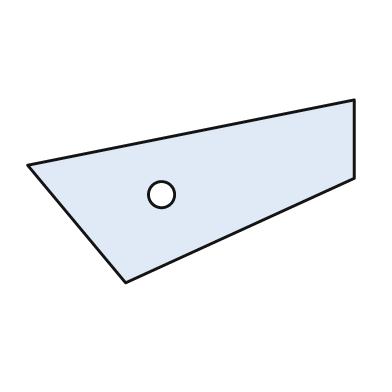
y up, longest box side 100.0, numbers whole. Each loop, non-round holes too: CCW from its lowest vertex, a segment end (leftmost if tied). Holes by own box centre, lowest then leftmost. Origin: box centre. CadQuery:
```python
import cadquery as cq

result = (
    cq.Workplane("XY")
    .moveTo(-20.0, -28.0)
    .lineTo(50.0, 4.0)
    .lineTo(50.0, 28.0)
    .lineTo(-50.0, 8.0)
    .close()
    .moveTo(-9.0, -1.0)
    .circle(4.0)
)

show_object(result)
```